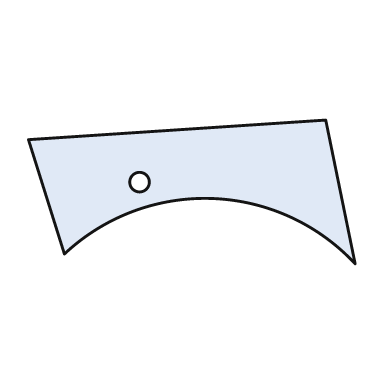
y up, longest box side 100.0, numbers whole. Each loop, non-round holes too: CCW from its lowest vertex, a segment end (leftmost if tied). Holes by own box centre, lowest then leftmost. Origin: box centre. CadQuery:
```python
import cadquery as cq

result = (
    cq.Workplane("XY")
    .moveTo(50.0, -22.0)
    .lineTo(41.0, 22.0)
    .lineTo(-50.0, 16.0)
    .lineTo(-39.0, -19.0)
    .threePointArc((6.0, -2.0), (50.0, -22.0))
    .close()
    .moveTo(-16.0, 3.0)
    .circle(3.0)
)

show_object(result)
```